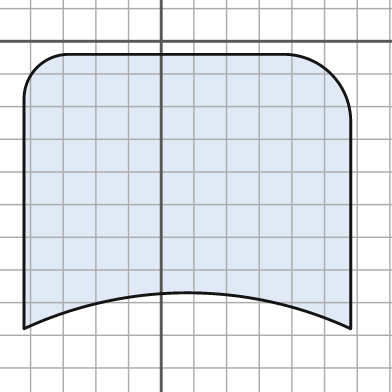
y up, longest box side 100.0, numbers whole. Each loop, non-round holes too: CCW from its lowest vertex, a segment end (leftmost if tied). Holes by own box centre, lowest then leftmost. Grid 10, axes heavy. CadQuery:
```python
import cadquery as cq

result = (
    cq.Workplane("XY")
    .moveTo(-42.0, -88.0)
    .threePointArc((8.0, -77.0), (58.0, -88.0))
    .lineTo(58.0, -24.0)
    .threePointArc((52.0, -10.0), (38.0, -4.0))
    .lineTo(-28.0, -4.0)
    .threePointArc((-38.0, -8.0), (-42.0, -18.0))
    .close()
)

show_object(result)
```